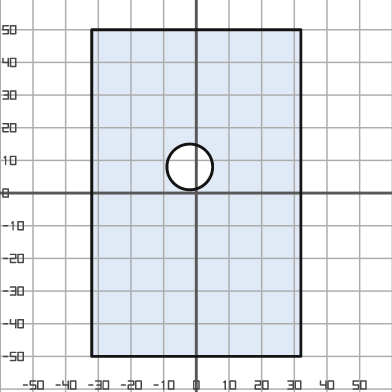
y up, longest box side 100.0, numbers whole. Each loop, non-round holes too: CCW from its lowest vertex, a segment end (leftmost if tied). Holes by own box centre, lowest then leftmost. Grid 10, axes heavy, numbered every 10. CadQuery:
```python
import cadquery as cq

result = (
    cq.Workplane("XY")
    .moveTo(-32.0, -50.0)
    .lineTo(32.0, -50.0)
    .lineTo(32.0, 50.0)
    .lineTo(-32.0, 50.0)
    .close()
    .moveTo(-2.0, 8.0)
    .circle(7.0)
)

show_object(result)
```